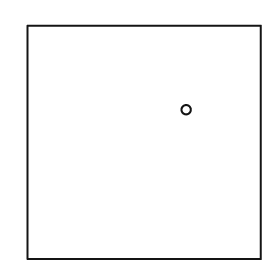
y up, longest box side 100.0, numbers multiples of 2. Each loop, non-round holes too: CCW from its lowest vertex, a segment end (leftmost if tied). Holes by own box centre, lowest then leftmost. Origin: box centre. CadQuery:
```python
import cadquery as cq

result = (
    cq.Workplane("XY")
    .moveTo(-50.0, -50.0)
    .lineTo(50.0, -50.0)
    .lineTo(50.0, 50.0)
    .lineTo(-50.0, 50.0)
    .close()
    .moveTo(18.0, 14.0)
    .circle(2.0)
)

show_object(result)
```